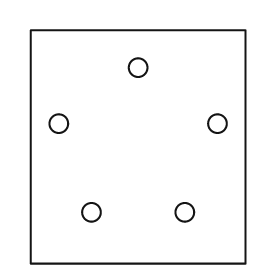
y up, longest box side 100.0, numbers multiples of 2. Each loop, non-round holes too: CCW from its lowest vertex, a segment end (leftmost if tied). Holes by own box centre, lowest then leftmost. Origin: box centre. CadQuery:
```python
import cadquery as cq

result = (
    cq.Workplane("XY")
    .moveTo(-46.0, -50.0)
    .lineTo(46.0, -50.0)
    .lineTo(46.0, 50.0)
    .lineTo(-46.0, 50.0)
    .close()
    .moveTo(-20.0, -28.0)
    .circle(4.0)
    .moveTo(20.0, -28.0)
    .circle(4.0)
    .moveTo(-34.0, 10.0)
    .circle(4.0)
    .moveTo(34.0, 10.0)
    .circle(4.0)
    .moveTo(0.0, 34.0)
    .circle(4.0)
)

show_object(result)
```